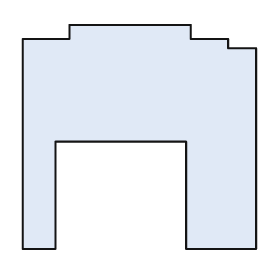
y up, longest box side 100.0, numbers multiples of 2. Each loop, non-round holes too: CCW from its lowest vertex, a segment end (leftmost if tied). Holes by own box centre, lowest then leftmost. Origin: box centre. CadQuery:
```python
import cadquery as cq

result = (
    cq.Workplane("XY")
    .moveTo(-50.0, -48.0)
    .lineTo(-36.0, -48.0)
    .lineTo(-36.0, -2.0)
    .lineTo(20.0, -2.0)
    .lineTo(20.0, -48.0)
    .lineTo(50.0, -48.0)
    .lineTo(50.0, 38.0)
    .lineTo(38.0, 38.0)
    .lineTo(38.0, 42.0)
    .lineTo(22.0, 42.0)
    .lineTo(22.0, 48.0)
    .lineTo(-30.0, 48.0)
    .lineTo(-30.0, 42.0)
    .lineTo(-50.0, 42.0)
    .close()
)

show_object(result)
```